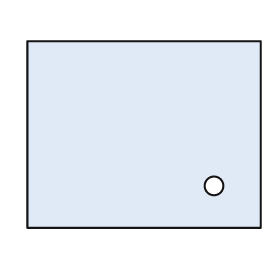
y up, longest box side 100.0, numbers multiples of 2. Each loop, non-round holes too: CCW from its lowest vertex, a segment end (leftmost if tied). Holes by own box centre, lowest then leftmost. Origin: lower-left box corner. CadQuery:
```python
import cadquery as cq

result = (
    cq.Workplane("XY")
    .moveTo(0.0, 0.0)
    .lineTo(100.0, 0.0)
    .lineTo(100.0, 80.0)
    .lineTo(0.0, 80.0)
    .close()
    .moveTo(80.0, 18.0)
    .circle(4.0)
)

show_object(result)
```